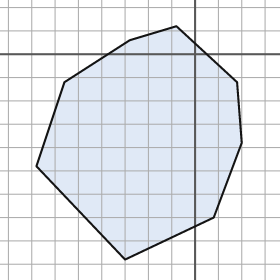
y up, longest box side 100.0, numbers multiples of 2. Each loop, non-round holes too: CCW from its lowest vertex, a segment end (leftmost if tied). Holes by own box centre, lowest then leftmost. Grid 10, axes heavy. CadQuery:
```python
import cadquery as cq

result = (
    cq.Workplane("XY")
    .moveTo(-30.0, -88.0)
    .lineTo(8.0, -70.0)
    .lineTo(20.0, -38.0)
    .lineTo(18.0, -12.0)
    .lineTo(-8.0, 12.0)
    .lineTo(-28.0, 6.0)
    .lineTo(-56.0, -12.0)
    .lineTo(-68.0, -48.0)
    .close()
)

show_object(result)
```